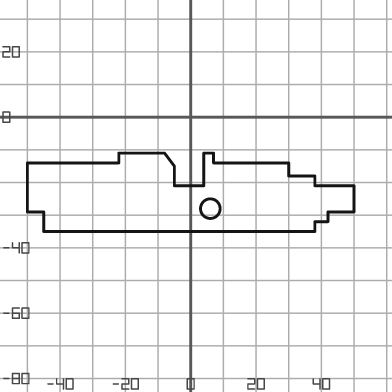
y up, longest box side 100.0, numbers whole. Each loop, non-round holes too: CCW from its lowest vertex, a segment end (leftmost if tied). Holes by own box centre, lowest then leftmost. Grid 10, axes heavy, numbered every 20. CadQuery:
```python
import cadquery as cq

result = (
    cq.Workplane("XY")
    .moveTo(-45.0, -35.0)
    .lineTo(38.0, -35.0)
    .lineTo(38.0, -32.0)
    .lineTo(42.0, -32.0)
    .lineTo(42.0, -29.0)
    .lineTo(50.0, -29.0)
    .lineTo(50.0, -21.0)
    .lineTo(38.0, -21.0)
    .lineTo(38.0, -18.0)
    .lineTo(30.0, -18.0)
    .lineTo(30.0, -14.0)
    .lineTo(7.0, -14.0)
    .lineTo(7.0, -11.0)
    .lineTo(4.0, -11.0)
    .lineTo(4.0, -21.0)
    .lineTo(-5.0, -21.0)
    .lineTo(-5.0, -15.0)
    .lineTo(-8.0, -11.0)
    .lineTo(-22.0, -11.0)
    .lineTo(-22.0, -14.0)
    .lineTo(-50.0, -14.0)
    .lineTo(-50.0, -29.0)
    .lineTo(-45.0, -29.0)
    .close()
    .moveTo(6.0, -28.0)
    .circle(3.0)
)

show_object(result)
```